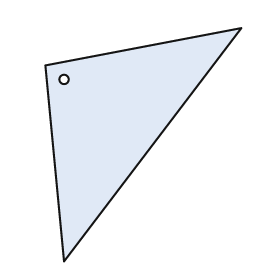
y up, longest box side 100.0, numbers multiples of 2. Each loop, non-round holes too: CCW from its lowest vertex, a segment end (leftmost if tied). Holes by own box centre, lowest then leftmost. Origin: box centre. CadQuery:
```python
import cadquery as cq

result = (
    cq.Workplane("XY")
    .moveTo(-34.0, -50.0)
    .lineTo(42.0, 50.0)
    .lineTo(-42.0, 34.0)
    .close()
    .moveTo(-34.0, 28.0)
    .circle(2.0)
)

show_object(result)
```